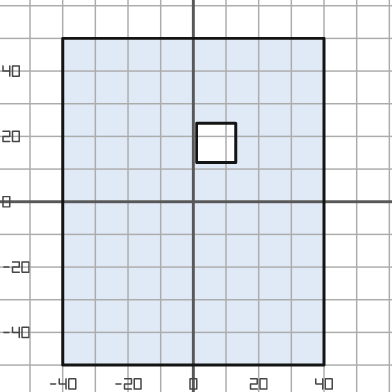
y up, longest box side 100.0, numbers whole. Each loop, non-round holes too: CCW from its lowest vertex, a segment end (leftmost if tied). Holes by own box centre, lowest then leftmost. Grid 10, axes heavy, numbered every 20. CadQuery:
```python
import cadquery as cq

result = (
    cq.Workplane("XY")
    .moveTo(-40.0, -50.0)
    .lineTo(40.0, -50.0)
    .lineTo(40.0, 50.0)
    .lineTo(-40.0, 50.0)
    .close()
    .moveTo(1.0, 12.0)
    .lineTo(13.0, 12.0)
    .lineTo(13.0, 24.0)
    .lineTo(1.0, 24.0)
    .close()
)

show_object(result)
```